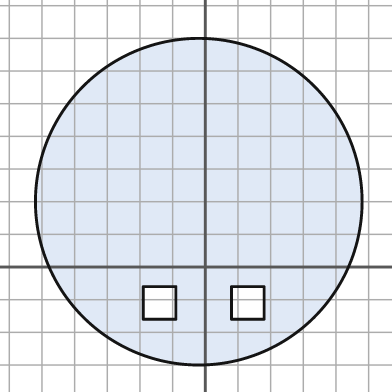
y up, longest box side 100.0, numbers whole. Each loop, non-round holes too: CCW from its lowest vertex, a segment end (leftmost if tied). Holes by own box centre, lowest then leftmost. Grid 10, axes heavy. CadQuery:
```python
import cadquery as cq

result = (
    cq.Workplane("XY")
    .moveTo(-2.0, 20.0)
    .circle(50.0)
    .moveTo(-19.0, -16.0)
    .lineTo(-9.0, -16.0)
    .lineTo(-9.0, -6.0)
    .lineTo(-19.0, -6.0)
    .close()
    .moveTo(8.0, -16.0)
    .lineTo(18.0, -16.0)
    .lineTo(18.0, -6.0)
    .lineTo(8.0, -6.0)
    .close()
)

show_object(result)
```